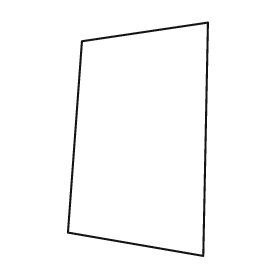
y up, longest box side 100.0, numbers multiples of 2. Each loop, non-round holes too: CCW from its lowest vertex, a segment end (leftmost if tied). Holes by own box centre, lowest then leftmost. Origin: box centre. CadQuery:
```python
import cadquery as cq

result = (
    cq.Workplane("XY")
    .moveTo(28.0, -50.0)
    .lineTo(30.0, 50.0)
    .lineTo(-24.0, 42.0)
    .lineTo(-30.0, -40.0)
    .close()
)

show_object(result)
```